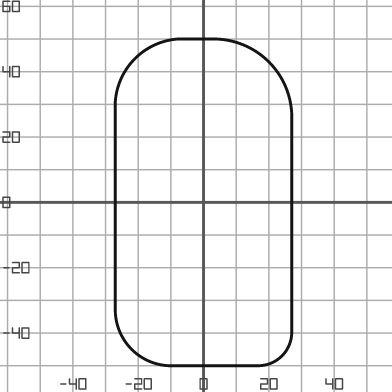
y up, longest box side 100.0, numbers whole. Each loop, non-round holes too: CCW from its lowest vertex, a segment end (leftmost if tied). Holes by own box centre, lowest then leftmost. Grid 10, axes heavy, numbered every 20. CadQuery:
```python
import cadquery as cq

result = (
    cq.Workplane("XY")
    .moveTo(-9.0, -50.0)
    .lineTo(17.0, -50.0)
    .threePointArc((24.0, -47.0), (27.0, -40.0))
    .lineTo(27.0, 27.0)
    .threePointArc((20.0, 43.0), (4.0, 50.0))
    .lineTo(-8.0, 50.0)
    .threePointArc((-21.0, 44.0), (-27.0, 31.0))
    .lineTo(-27.0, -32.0)
    .threePointArc((-22.0, -45.0), (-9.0, -50.0))
    .close()
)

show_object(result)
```